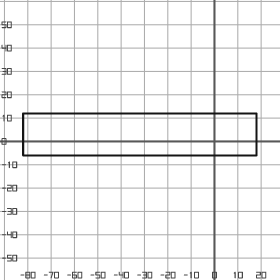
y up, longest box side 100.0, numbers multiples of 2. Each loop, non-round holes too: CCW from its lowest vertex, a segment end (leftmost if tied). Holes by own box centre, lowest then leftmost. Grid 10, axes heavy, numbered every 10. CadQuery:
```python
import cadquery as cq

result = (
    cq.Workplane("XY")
    .moveTo(-82.0, -6.0)
    .lineTo(18.0, -6.0)
    .lineTo(18.0, 12.0)
    .lineTo(-82.0, 12.0)
    .close()
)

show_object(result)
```